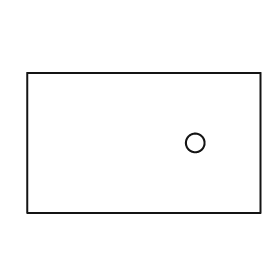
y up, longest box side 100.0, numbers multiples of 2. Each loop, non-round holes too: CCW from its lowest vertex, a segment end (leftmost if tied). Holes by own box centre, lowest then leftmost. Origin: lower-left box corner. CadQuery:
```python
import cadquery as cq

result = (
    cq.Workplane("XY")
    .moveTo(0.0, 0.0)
    .lineTo(100.0, 0.0)
    .lineTo(100.0, 60.0)
    .lineTo(0.0, 60.0)
    .close()
    .moveTo(72.0, 30.0)
    .circle(4.0)
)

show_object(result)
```